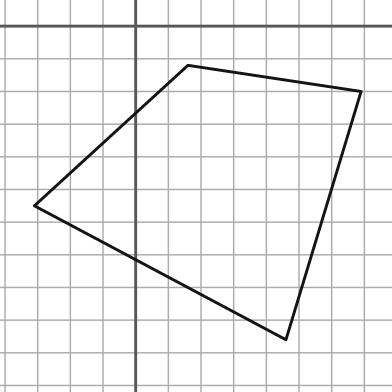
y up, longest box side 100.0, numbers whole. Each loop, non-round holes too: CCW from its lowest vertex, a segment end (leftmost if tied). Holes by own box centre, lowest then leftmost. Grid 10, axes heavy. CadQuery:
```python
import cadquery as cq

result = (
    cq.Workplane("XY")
    .moveTo(46.0, -96.0)
    .lineTo(69.0, -20.0)
    .lineTo(16.0, -12.0)
    .lineTo(-31.0, -55.0)
    .close()
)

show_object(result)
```